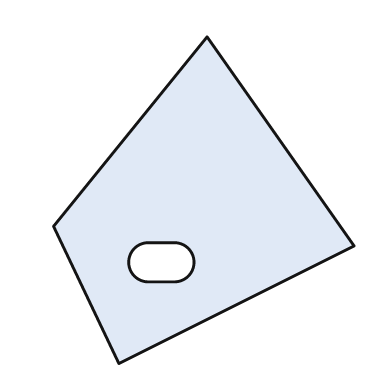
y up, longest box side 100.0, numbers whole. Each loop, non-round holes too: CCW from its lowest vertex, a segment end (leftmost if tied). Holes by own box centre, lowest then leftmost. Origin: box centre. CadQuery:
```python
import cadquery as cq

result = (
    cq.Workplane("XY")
    .moveTo(-26.0, -50.0)
    .lineTo(46.0, -14.0)
    .lineTo(1.0, 50.0)
    .lineTo(-46.0, -8.0)
    .close()
    .moveTo(-17.0, -25.0)
    .lineTo(-9.0, -25.0)
    .threePointArc((-3.0, -19.0), (-9.0, -13.0))
    .lineTo(-17.0, -13.0)
    .threePointArc((-23.0, -19.0), (-17.0, -25.0))
    .close()
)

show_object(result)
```